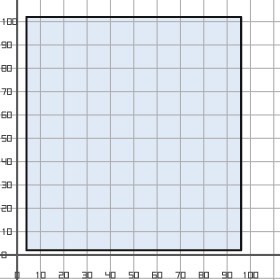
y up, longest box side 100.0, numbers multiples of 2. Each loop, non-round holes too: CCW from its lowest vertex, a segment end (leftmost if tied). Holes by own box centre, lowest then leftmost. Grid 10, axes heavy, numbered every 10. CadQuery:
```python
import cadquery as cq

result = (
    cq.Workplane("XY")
    .moveTo(4.0, 2.0)
    .lineTo(96.0, 2.0)
    .lineTo(96.0, 102.0)
    .lineTo(4.0, 102.0)
    .close()
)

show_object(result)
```